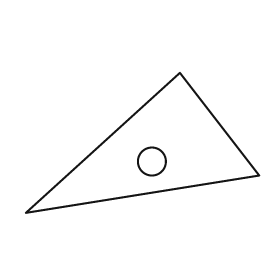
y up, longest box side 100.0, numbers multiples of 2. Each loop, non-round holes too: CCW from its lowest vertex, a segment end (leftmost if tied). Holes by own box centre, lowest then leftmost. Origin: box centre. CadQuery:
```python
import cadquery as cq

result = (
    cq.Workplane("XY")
    .moveTo(-50.0, -30.0)
    .lineTo(50.0, -14.0)
    .lineTo(16.0, 30.0)
    .close()
    .moveTo(4.0, -8.0)
    .circle(6.0)
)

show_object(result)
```